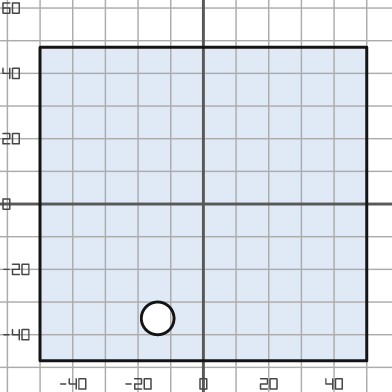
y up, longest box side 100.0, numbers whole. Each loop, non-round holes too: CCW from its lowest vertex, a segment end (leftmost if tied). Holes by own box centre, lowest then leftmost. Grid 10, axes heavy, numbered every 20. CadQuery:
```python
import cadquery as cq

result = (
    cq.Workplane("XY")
    .moveTo(-50.0, -48.0)
    .lineTo(50.0, -48.0)
    .lineTo(50.0, 48.0)
    .lineTo(-50.0, 48.0)
    .close()
    .moveTo(-14.0, -35.0)
    .circle(5.0)
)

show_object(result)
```